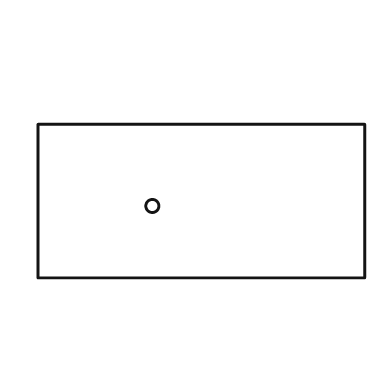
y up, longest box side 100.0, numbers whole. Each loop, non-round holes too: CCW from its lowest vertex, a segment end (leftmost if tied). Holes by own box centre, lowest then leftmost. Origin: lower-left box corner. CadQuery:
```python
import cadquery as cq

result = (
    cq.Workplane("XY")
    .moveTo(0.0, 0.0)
    .lineTo(100.0, 0.0)
    .lineTo(100.0, 47.0)
    .lineTo(0.0, 47.0)
    .close()
    .moveTo(35.0, 22.0)
    .circle(2.0)
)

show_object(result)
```